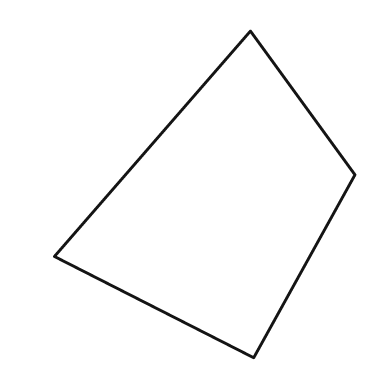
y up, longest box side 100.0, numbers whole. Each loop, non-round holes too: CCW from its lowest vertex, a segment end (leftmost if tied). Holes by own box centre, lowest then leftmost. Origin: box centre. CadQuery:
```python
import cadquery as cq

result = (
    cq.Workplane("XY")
    .moveTo(15.0, -50.0)
    .lineTo(46.0, 6.0)
    .lineTo(14.0, 50.0)
    .lineTo(-46.0, -19.0)
    .close()
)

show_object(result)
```